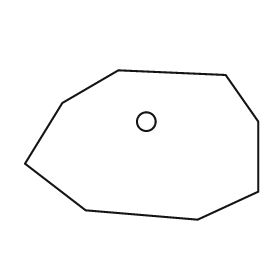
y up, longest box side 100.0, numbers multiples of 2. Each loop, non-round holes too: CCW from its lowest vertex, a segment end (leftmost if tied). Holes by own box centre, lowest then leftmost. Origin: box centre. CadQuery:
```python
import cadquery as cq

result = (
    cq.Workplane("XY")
    .moveTo(24.0, -32.0)
    .lineTo(50.0, -20.0)
    .lineTo(50.0, 10.0)
    .lineTo(36.0, 30.0)
    .lineTo(-10.0, 32.0)
    .lineTo(-34.0, 18.0)
    .lineTo(-50.0, -8.0)
    .lineTo(-24.0, -28.0)
    .close()
    .moveTo(2.0, 10.0)
    .circle(4.0)
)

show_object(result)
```